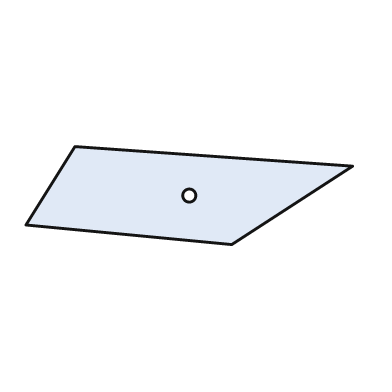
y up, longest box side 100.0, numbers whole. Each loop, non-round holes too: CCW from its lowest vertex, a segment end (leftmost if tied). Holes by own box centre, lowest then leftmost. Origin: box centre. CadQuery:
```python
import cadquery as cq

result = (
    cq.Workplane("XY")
    .moveTo(13.0, -15.0)
    .lineTo(50.0, 9.0)
    .lineTo(-35.0, 15.0)
    .lineTo(-50.0, -9.0)
    .close()
    .moveTo(0.0, 0.0)
    .circle(2.0)
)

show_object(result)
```